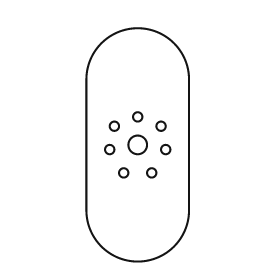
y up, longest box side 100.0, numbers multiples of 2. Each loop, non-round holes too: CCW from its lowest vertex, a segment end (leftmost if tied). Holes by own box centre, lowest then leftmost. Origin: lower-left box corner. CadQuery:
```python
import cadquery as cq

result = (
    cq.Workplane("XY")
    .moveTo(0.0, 22.0)
    .threePointArc((22.0, 0.0), (44.0, 22.0))
    .lineTo(44.0, 78.0)
    .threePointArc((22.0, 100.0), (0.0, 78.0))
    .close()
    .moveTo(16.0, 38.0)
    .circle(2.0)
    .moveTo(28.0, 38.0)
    .circle(2.0)
    .moveTo(10.0, 48.0)
    .circle(2.0)
    .moveTo(34.0, 48.0)
    .circle(2.0)
    .moveTo(22.0, 50.0)
    .circle(4.0)
    .moveTo(12.0, 58.0)
    .circle(2.0)
    .moveTo(32.0, 58.0)
    .circle(2.0)
    .moveTo(22.0, 62.0)
    .circle(2.0)
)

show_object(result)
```